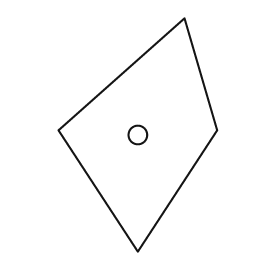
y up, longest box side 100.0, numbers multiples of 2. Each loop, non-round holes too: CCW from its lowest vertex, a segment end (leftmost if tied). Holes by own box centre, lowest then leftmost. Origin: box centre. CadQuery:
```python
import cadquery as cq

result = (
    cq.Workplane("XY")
    .moveTo(0.0, -50.0)
    .lineTo(34.0, 2.0)
    .lineTo(20.0, 50.0)
    .lineTo(-34.0, 2.0)
    .close()
    .moveTo(0.0, 0.0)
    .circle(4.0)
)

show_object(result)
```